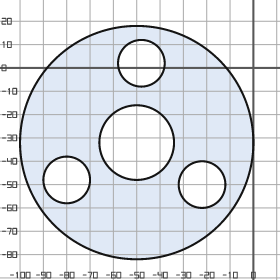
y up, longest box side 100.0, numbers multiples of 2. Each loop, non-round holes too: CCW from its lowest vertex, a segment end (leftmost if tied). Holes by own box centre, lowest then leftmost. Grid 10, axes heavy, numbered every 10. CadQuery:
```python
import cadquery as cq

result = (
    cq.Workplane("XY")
    .moveTo(-50.0, -32.0)
    .circle(50.0)
    .moveTo(-22.0, -50.0)
    .circle(10.0)
    .moveTo(-80.0, -48.0)
    .circle(10.0)
    .moveTo(-50.0, -32.0)
    .circle(16.0)
    .moveTo(-48.0, 2.0)
    .circle(10.0)
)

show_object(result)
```